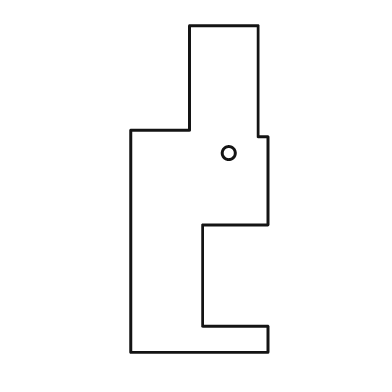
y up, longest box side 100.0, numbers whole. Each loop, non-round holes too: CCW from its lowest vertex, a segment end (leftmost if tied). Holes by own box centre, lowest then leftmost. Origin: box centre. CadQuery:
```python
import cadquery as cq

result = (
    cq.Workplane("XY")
    .moveTo(-21.0, -50.0)
    .lineTo(21.0, -50.0)
    .lineTo(21.0, -42.0)
    .lineTo(1.0, -42.0)
    .lineTo(1.0, -11.0)
    .lineTo(21.0, -11.0)
    .lineTo(21.0, 16.0)
    .lineTo(18.0, 16.0)
    .lineTo(18.0, 50.0)
    .lineTo(-3.0, 50.0)
    .lineTo(-3.0, 18.0)
    .lineTo(-21.0, 18.0)
    .close()
    .moveTo(9.0, 11.0)
    .circle(2.0)
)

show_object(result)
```